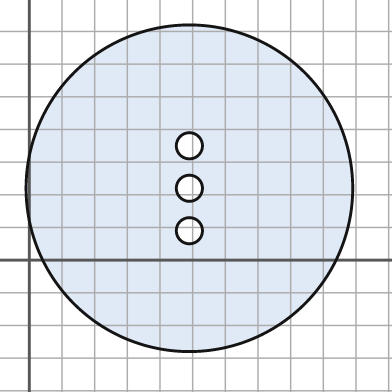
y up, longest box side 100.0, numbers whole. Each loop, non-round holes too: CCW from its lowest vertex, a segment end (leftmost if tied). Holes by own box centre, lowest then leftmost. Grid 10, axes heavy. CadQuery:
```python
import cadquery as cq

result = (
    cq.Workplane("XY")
    .moveTo(49.0, 22.0)
    .circle(50.0)
    .moveTo(49.0, 9.0)
    .circle(4.0)
    .moveTo(49.0, 22.0)
    .circle(4.0)
    .moveTo(49.0, 35.0)
    .circle(4.0)
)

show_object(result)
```